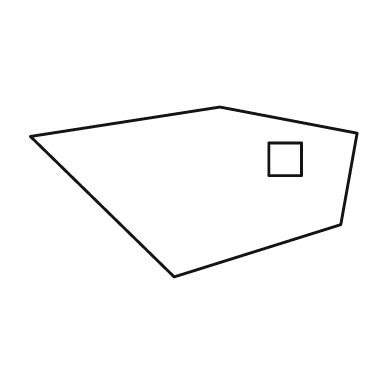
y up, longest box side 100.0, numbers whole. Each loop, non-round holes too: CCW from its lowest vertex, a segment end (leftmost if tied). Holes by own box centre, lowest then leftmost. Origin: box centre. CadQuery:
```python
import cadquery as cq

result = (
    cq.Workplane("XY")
    .moveTo(-6.0, -26.0)
    .lineTo(45.0, -10.0)
    .lineTo(50.0, 18.0)
    .lineTo(8.0, 26.0)
    .lineTo(-50.0, 17.0)
    .close()
    .moveTo(23.0, 5.0)
    .lineTo(33.0, 5.0)
    .lineTo(33.0, 15.0)
    .lineTo(23.0, 15.0)
    .close()
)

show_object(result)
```